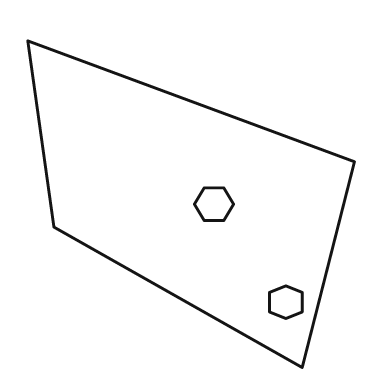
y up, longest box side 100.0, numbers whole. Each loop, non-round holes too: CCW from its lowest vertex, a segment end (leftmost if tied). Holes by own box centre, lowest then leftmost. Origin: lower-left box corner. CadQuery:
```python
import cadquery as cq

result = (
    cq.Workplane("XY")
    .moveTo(84.0, 0.0)
    .lineTo(100.0, 63.0)
    .lineTo(0.0, 100.0)
    .lineTo(8.0, 43.0)
    .close()
    .moveTo(79.0, 15.0)
    .lineTo(84.0, 17.0)
    .lineTo(84.0, 23.0)
    .lineTo(79.0, 25.0)
    .lineTo(74.0, 23.0)
    .lineTo(74.0, 17.0)
    .close()
    .moveTo(54.0, 45.0)
    .lineTo(60.0, 45.0)
    .lineTo(63.0, 50.0)
    .lineTo(60.0, 55.0)
    .lineTo(54.0, 55.0)
    .lineTo(51.0, 50.0)
    .close()
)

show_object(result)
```